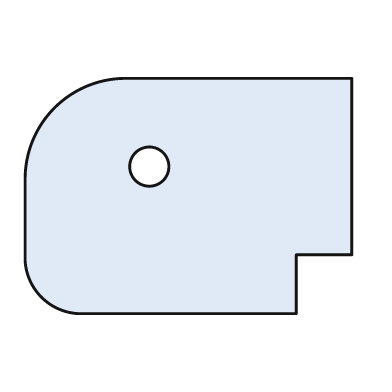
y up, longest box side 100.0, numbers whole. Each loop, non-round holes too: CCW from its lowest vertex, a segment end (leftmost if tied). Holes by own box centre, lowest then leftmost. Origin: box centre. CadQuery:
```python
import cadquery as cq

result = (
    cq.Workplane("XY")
    .moveTo(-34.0, -36.0)
    .lineTo(33.0, -36.0)
    .lineTo(33.0, -18.0)
    .lineTo(50.0, -18.0)
    .lineTo(50.0, 36.0)
    .lineTo(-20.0, 36.0)
    .threePointArc((-41.0, 27.0), (-50.0, 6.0))
    .lineTo(-50.0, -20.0)
    .threePointArc((-45.0, -31.0), (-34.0, -36.0))
    .close()
    .moveTo(-12.0, 9.0)
    .circle(6.0)
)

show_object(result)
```